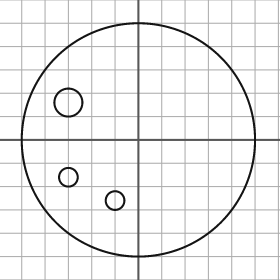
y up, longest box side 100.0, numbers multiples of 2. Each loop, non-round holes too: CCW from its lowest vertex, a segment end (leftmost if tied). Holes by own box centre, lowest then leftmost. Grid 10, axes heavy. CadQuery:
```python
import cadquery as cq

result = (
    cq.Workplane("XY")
    .moveTo(0.0, 0.0)
    .circle(50.0)
    .moveTo(-10.0, -26.0)
    .circle(4.0)
    .moveTo(-30.0, -16.0)
    .circle(4.0)
    .moveTo(-30.0, 16.0)
    .circle(6.0)
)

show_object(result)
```